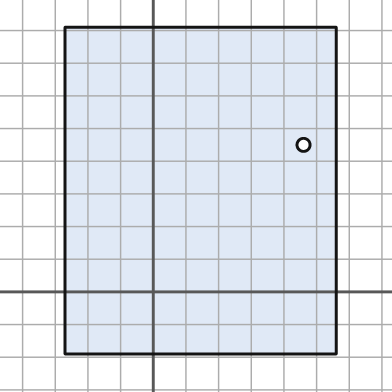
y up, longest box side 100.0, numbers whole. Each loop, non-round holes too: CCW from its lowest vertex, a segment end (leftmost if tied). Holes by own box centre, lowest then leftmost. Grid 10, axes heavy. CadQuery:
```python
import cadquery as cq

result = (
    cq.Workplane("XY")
    .moveTo(-27.0, -19.0)
    .lineTo(56.0, -19.0)
    .lineTo(56.0, 81.0)
    .lineTo(-27.0, 81.0)
    .close()
    .moveTo(46.0, 45.0)
    .circle(2.0)
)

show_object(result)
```